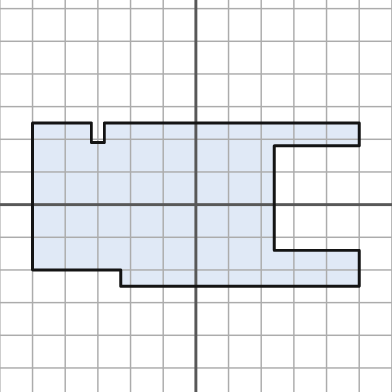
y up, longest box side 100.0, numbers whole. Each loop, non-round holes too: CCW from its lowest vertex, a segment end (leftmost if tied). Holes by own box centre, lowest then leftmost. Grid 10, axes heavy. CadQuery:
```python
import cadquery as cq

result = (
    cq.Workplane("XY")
    .moveTo(-23.0, -25.0)
    .lineTo(50.0, -25.0)
    .lineTo(50.0, -14.0)
    .lineTo(24.0, -14.0)
    .lineTo(24.0, 18.0)
    .lineTo(50.0, 18.0)
    .lineTo(50.0, 25.0)
    .lineTo(-28.0, 25.0)
    .lineTo(-28.0, 19.0)
    .lineTo(-32.0, 19.0)
    .lineTo(-32.0, 25.0)
    .lineTo(-50.0, 25.0)
    .lineTo(-50.0, -20.0)
    .lineTo(-23.0, -20.0)
    .close()
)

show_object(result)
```